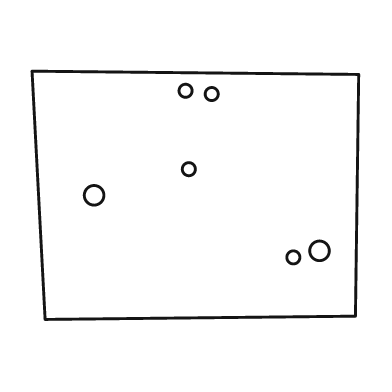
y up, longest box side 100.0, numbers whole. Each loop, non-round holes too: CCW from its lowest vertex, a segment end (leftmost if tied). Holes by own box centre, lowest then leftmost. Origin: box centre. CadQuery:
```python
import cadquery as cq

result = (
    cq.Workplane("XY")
    .moveTo(-46.0, -38.0)
    .lineTo(49.0, -37.0)
    .lineTo(50.0, 37.0)
    .lineTo(-50.0, 38.0)
    .close()
    .moveTo(30.0, -19.0)
    .circle(2.0)
    .moveTo(38.0, -17.0)
    .circle(3.0)
    .moveTo(-31.0, 0.0)
    .circle(3.0)
    .moveTo(-2.0, 8.0)
    .circle(2.0)
    .moveTo(5.0, 31.0)
    .circle(2.0)
    .moveTo(-3.0, 32.0)
    .circle(2.0)
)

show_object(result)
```